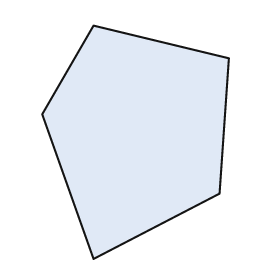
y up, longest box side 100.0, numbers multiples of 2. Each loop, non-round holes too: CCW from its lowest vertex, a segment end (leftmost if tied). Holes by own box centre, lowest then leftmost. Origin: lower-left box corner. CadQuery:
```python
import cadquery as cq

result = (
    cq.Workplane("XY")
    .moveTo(22.0, 0.0)
    .lineTo(76.0, 28.0)
    .lineTo(80.0, 86.0)
    .lineTo(22.0, 100.0)
    .lineTo(0.0, 62.0)
    .close()
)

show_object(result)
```